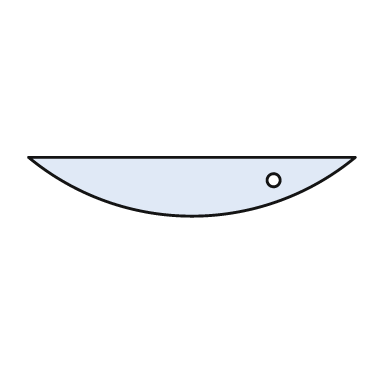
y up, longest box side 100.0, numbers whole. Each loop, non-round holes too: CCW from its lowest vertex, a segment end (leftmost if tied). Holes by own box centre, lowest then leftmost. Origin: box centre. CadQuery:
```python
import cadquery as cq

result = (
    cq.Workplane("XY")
    .moveTo(-50.0, 9.0)
    .threePointArc((0.0, -9.0), (50.0, 9.0))
    .close()
    .moveTo(25.0, 2.0)
    .circle(2.0)
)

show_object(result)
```